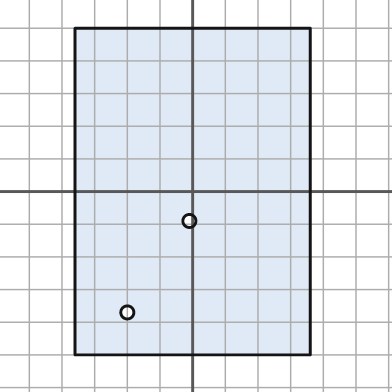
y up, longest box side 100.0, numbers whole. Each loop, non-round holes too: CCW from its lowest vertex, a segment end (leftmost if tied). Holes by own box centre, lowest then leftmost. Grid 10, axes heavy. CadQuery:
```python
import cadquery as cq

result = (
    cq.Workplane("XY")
    .moveTo(-36.0, -50.0)
    .lineTo(36.0, -50.0)
    .lineTo(36.0, 50.0)
    .lineTo(-36.0, 50.0)
    .close()
    .moveTo(-20.0, -37.0)
    .circle(2.0)
    .moveTo(-1.0, -9.0)
    .circle(2.0)
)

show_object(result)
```